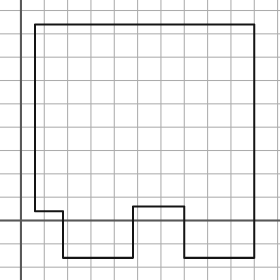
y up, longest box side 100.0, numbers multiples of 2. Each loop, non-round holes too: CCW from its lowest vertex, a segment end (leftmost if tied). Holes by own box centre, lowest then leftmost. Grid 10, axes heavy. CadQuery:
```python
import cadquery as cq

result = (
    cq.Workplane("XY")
    .moveTo(18.0, -16.0)
    .lineTo(48.0, -16.0)
    .lineTo(48.0, 6.0)
    .lineTo(70.0, 6.0)
    .lineTo(70.0, -16.0)
    .lineTo(100.0, -16.0)
    .lineTo(100.0, 84.0)
    .lineTo(6.0, 84.0)
    .lineTo(6.0, 4.0)
    .lineTo(18.0, 4.0)
    .close()
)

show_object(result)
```